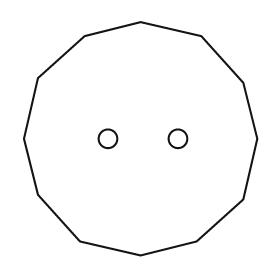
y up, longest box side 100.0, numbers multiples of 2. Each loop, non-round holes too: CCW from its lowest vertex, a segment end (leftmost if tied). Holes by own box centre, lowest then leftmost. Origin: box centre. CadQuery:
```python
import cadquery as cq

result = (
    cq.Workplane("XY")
    .moveTo(0.0, -50.0)
    .lineTo(24.0, -44.0)
    .lineTo(44.0, -26.0)
    .lineTo(50.0, 0.0)
    .lineTo(44.0, 24.0)
    .lineTo(26.0, 44.0)
    .lineTo(0.0, 50.0)
    .lineTo(-24.0, 44.0)
    .lineTo(-44.0, 26.0)
    .lineTo(-50.0, 0.0)
    .lineTo(-44.0, -24.0)
    .lineTo(-26.0, -44.0)
    .close()
    .moveTo(-14.0, 0.0)
    .circle(4.0)
    .moveTo(16.0, 0.0)
    .circle(4.0)
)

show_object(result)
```